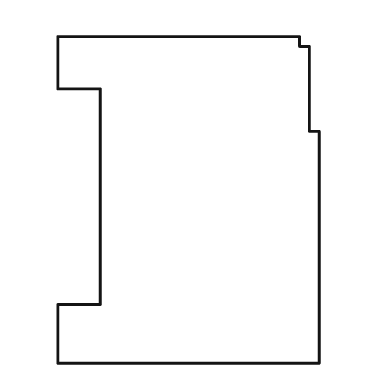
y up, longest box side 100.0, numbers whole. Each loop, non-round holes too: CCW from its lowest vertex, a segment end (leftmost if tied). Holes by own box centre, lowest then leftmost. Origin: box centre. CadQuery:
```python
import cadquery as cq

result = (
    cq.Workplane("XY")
    .moveTo(-40.0, -50.0)
    .lineTo(40.0, -50.0)
    .lineTo(40.0, 21.0)
    .lineTo(37.0, 21.0)
    .lineTo(37.0, 47.0)
    .lineTo(34.0, 47.0)
    .lineTo(34.0, 50.0)
    .lineTo(-40.0, 50.0)
    .lineTo(-40.0, 34.0)
    .lineTo(-27.0, 34.0)
    .lineTo(-27.0, -32.0)
    .lineTo(-40.0, -32.0)
    .close()
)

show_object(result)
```